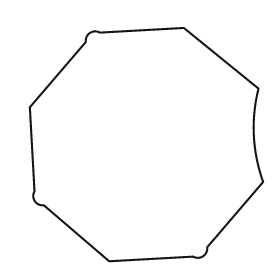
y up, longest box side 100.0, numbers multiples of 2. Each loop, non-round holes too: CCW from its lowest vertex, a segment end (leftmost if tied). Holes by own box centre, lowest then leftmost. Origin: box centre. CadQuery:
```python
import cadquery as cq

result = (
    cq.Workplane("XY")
    .moveTo(-16.0, -50.0)
    .lineTo(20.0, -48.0)
    .threePointArc((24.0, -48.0), (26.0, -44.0))
    .lineTo(50.0, -16.0)
    .threePointArc((46.0, 4.0), (48.0, 24.0))
    .lineTo(16.0, 50.0)
    .lineTo(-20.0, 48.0)
    .threePointArc((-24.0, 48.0), (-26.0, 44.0))
    .lineTo(-50.0, 16.0)
    .lineTo(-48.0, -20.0)
    .threePointArc((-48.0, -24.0), (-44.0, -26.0))
    .close()
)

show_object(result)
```